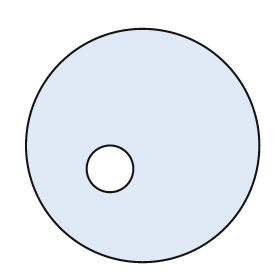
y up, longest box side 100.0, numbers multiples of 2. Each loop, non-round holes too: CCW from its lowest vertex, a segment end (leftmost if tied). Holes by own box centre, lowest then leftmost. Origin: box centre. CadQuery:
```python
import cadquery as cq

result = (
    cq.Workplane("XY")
    .moveTo(0.0, 0.0)
    .circle(50.0)
    .moveTo(-14.0, -10.0)
    .circle(10.0)
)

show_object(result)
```